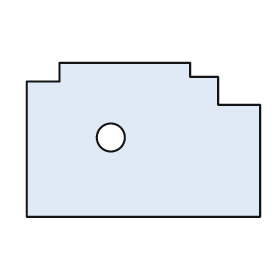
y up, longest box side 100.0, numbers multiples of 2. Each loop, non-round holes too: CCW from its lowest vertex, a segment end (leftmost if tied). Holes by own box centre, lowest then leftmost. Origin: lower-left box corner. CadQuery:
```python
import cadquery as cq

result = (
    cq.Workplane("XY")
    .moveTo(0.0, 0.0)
    .lineTo(100.0, 0.0)
    .lineTo(100.0, 48.0)
    .lineTo(82.0, 48.0)
    .lineTo(82.0, 60.0)
    .lineTo(70.0, 60.0)
    .lineTo(70.0, 66.0)
    .lineTo(14.0, 66.0)
    .lineTo(14.0, 58.0)
    .lineTo(0.0, 58.0)
    .close()
    .moveTo(36.0, 34.0)
    .circle(6.0)
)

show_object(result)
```